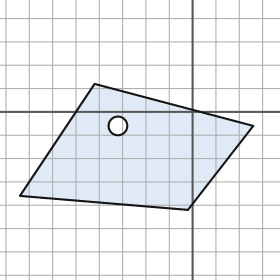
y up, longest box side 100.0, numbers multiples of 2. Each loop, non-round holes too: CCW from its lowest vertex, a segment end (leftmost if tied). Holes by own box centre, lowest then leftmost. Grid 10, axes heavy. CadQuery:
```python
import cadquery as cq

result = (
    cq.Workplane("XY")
    .moveTo(-2.0, -42.0)
    .lineTo(26.0, -6.0)
    .lineTo(-42.0, 12.0)
    .lineTo(-74.0, -36.0)
    .close()
    .moveTo(-32.0, -6.0)
    .circle(4.0)
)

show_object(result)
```